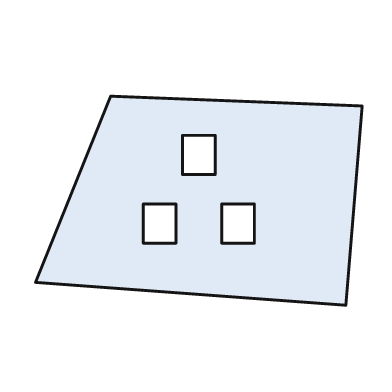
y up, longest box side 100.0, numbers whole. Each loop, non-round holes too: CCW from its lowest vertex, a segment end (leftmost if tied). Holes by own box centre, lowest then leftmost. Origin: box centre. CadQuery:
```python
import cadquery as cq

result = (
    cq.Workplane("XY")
    .moveTo(45.0, -32.0)
    .lineTo(50.0, 29.0)
    .lineTo(-27.0, 32.0)
    .lineTo(-50.0, -25.0)
    .close()
    .moveTo(-17.0, -13.0)
    .lineTo(-7.0, -13.0)
    .lineTo(-7.0, -1.0)
    .lineTo(-17.0, -1.0)
    .close()
    .moveTo(7.0, -13.0)
    .lineTo(17.0, -13.0)
    .lineTo(17.0, -1.0)
    .lineTo(7.0, -1.0)
    .close()
    .moveTo(-5.0, 8.0)
    .lineTo(5.0, 8.0)
    .lineTo(5.0, 20.0)
    .lineTo(-5.0, 20.0)
    .close()
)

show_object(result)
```